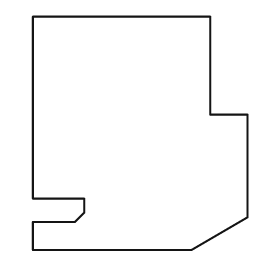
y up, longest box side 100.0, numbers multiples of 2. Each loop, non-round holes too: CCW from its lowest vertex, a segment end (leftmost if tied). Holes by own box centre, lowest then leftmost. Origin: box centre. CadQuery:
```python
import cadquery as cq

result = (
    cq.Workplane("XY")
    .moveTo(-46.0, -50.0)
    .lineTo(22.0, -50.0)
    .lineTo(46.0, -36.0)
    .lineTo(46.0, 8.0)
    .lineTo(30.0, 8.0)
    .lineTo(30.0, 50.0)
    .lineTo(-46.0, 50.0)
    .lineTo(-46.0, -28.0)
    .lineTo(-24.0, -28.0)
    .lineTo(-24.0, -34.0)
    .lineTo(-28.0, -38.0)
    .lineTo(-46.0, -38.0)
    .close()
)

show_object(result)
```